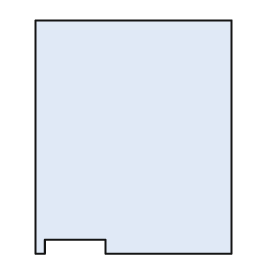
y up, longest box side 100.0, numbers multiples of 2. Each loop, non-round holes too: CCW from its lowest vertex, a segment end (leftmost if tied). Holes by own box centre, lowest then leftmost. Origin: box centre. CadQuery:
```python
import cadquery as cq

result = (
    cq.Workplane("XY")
    .moveTo(-42.0, -50.0)
    .lineTo(-38.0, -50.0)
    .lineTo(-38.0, -44.0)
    .lineTo(-12.0, -44.0)
    .lineTo(-12.0, -50.0)
    .lineTo(42.0, -50.0)
    .lineTo(42.0, 50.0)
    .lineTo(-42.0, 50.0)
    .close()
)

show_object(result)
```